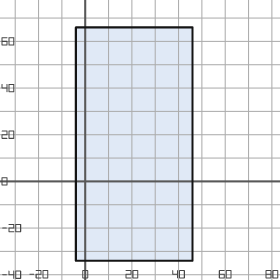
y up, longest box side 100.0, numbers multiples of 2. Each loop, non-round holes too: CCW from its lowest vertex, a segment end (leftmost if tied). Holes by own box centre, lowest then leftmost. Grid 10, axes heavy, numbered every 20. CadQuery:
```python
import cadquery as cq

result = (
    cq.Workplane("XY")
    .moveTo(-4.0, -34.0)
    .lineTo(46.0, -34.0)
    .lineTo(46.0, 66.0)
    .lineTo(-4.0, 66.0)
    .close()
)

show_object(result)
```